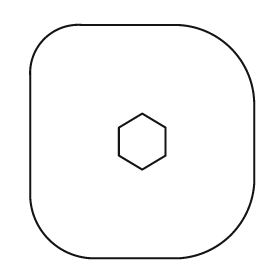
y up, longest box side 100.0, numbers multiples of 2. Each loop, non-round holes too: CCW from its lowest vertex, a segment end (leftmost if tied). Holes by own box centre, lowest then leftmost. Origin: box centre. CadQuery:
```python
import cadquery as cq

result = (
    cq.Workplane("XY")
    .moveTo(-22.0, -50.0)
    .lineTo(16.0, -50.0)
    .threePointArc((38.0, -40.0), (48.0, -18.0))
    .lineTo(48.0, 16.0)
    .threePointArc((38.0, 40.0), (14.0, 50.0))
    .lineTo(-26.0, 50.0)
    .threePointArc((-42.0, 44.0), (-48.0, 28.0))
    .lineTo(-48.0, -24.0)
    .threePointArc((-40.0, -42.0), (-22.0, -50.0))
    .close()
    .moveTo(0.0, -12.0)
    .lineTo(10.0, -6.0)
    .lineTo(10.0, 6.0)
    .lineTo(0.0, 12.0)
    .lineTo(-10.0, 6.0)
    .lineTo(-10.0, -6.0)
    .close()
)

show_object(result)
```